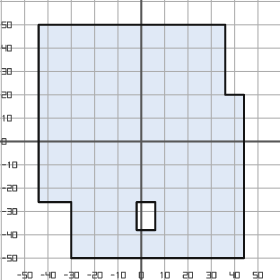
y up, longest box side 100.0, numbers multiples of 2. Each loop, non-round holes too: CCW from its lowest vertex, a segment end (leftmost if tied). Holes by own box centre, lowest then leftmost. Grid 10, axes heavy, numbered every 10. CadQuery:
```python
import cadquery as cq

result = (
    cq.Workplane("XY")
    .moveTo(-30.0, -50.0)
    .lineTo(44.0, -50.0)
    .lineTo(44.0, 20.0)
    .lineTo(36.0, 20.0)
    .lineTo(36.0, 50.0)
    .lineTo(-44.0, 50.0)
    .lineTo(-44.0, -26.0)
    .lineTo(-30.0, -26.0)
    .close()
    .moveTo(-2.0, -38.0)
    .lineTo(6.0, -38.0)
    .lineTo(6.0, -26.0)
    .lineTo(-2.0, -26.0)
    .close()
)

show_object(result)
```